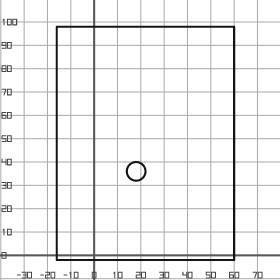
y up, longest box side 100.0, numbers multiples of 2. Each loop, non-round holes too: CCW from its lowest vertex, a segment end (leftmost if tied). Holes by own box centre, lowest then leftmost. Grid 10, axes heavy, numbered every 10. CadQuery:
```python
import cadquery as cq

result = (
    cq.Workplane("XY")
    .moveTo(-16.0, -2.0)
    .lineTo(60.0, -2.0)
    .lineTo(60.0, 98.0)
    .lineTo(-16.0, 98.0)
    .close()
    .moveTo(18.0, 36.0)
    .circle(4.0)
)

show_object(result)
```